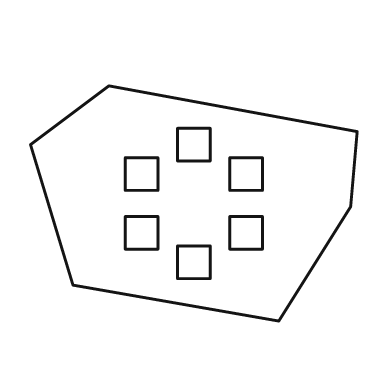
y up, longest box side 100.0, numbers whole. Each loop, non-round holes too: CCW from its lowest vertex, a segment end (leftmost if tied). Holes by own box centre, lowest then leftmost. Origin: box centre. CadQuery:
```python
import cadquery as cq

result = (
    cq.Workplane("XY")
    .moveTo(26.0, -36.0)
    .lineTo(48.0, -1.0)
    .lineTo(50.0, 22.0)
    .lineTo(-26.0, 36.0)
    .lineTo(-50.0, 18.0)
    .lineTo(-37.0, -25.0)
    .close()
    .moveTo(-5.0, -23.0)
    .lineTo(5.0, -23.0)
    .lineTo(5.0, -13.0)
    .lineTo(-5.0, -13.0)
    .close()
    .moveTo(-21.0, -14.0)
    .lineTo(-11.0, -14.0)
    .lineTo(-11.0, -4.0)
    .lineTo(-21.0, -4.0)
    .close()
    .moveTo(11.0, -14.0)
    .lineTo(21.0, -14.0)
    .lineTo(21.0, -4.0)
    .lineTo(11.0, -4.0)
    .close()
    .moveTo(-21.0, 4.0)
    .lineTo(-11.0, 4.0)
    .lineTo(-11.0, 14.0)
    .lineTo(-21.0, 14.0)
    .close()
    .moveTo(11.0, 4.0)
    .lineTo(21.0, 4.0)
    .lineTo(21.0, 14.0)
    .lineTo(11.0, 14.0)
    .close()
    .moveTo(-5.0, 13.0)
    .lineTo(5.0, 13.0)
    .lineTo(5.0, 23.0)
    .lineTo(-5.0, 23.0)
    .close()
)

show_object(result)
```